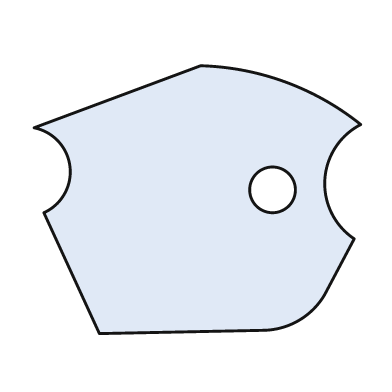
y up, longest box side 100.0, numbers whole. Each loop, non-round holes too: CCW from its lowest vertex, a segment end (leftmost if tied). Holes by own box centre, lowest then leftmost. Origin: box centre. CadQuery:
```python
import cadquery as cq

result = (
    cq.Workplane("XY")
    .moveTo(-30.0, -41.0)
    .lineTo(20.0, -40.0)
    .threePointArc((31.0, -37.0), (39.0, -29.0))
    .lineTo(48.0, -12.0)
    .threePointArc((39.0, 6.0), (50.0, 23.0))
    .threePointArc((27.0, 36.0), (1.0, 41.0))
    .lineTo(-50.0, 22.0)
    .threePointArc((-39.0, 10.0), (-47.0, -4.0))
    .close()
    .moveTo(23.0, 3.0)
    .circle(7.0)
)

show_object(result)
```